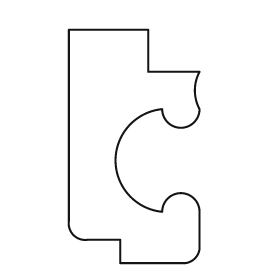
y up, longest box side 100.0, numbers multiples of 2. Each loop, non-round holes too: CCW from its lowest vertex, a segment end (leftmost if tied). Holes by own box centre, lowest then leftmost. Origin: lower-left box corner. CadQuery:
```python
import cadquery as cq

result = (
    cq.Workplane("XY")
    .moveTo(22.0, 0.0)
    .lineTo(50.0, 0.0)
    .threePointArc((54.0, 2.0), (56.0, 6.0))
    .lineTo(56.0, 22.0)
    .threePointArc((48.0, 30.0), (40.0, 22.0))
    .threePointArc((20.0, 44.0), (40.0, 66.0))
    .threePointArc((48.0, 58.0), (56.0, 66.0))
    .threePointArc((54.0, 74.0), (56.0, 82.0))
    .lineTo(34.0, 82.0)
    .lineTo(34.0, 100.0)
    .lineTo(0.0, 100.0)
    .lineTo(0.0, 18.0)
    .threePointArc((2.0, 12.0), (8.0, 10.0))
    .lineTo(22.0, 10.0)
    .close()
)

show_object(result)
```